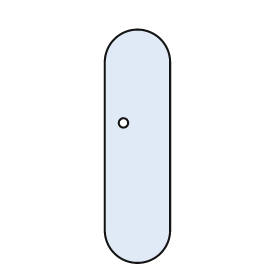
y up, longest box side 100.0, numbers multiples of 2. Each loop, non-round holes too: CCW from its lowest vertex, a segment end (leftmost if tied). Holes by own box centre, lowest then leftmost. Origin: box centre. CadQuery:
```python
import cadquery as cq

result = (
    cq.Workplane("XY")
    .moveTo(-14.0, -36.0)
    .threePointArc((0.0, -50.0), (14.0, -36.0))
    .lineTo(14.0, 36.0)
    .threePointArc((0.0, 50.0), (-14.0, 36.0))
    .close()
    .moveTo(-6.0, 10.0)
    .circle(2.0)
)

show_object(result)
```